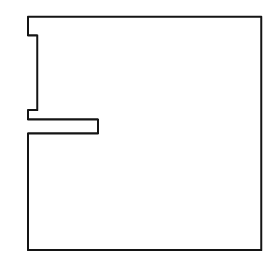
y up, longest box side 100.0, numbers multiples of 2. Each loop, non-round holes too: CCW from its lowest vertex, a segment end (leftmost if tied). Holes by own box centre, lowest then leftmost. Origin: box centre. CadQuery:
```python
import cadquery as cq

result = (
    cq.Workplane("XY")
    .moveTo(-50.0, -50.0)
    .lineTo(50.0, -50.0)
    .lineTo(50.0, 50.0)
    .lineTo(-50.0, 50.0)
    .lineTo(-50.0, 42.0)
    .lineTo(-46.0, 42.0)
    .lineTo(-46.0, 10.0)
    .lineTo(-50.0, 10.0)
    .lineTo(-50.0, 6.0)
    .lineTo(-20.0, 6.0)
    .lineTo(-20.0, 0.0)
    .lineTo(-50.0, 0.0)
    .close()
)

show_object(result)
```